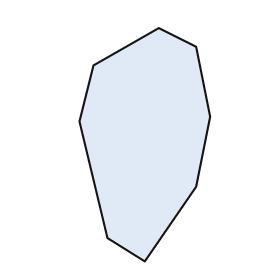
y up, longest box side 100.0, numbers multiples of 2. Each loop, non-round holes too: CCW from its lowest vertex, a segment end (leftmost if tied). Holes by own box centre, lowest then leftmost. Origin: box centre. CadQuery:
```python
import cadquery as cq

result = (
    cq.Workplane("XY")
    .moveTo(0.0, -50.0)
    .lineTo(22.0, -18.0)
    .lineTo(28.0, 12.0)
    .lineTo(22.0, 42.0)
    .lineTo(6.0, 50.0)
    .lineTo(-22.0, 34.0)
    .lineTo(-28.0, 10.0)
    .lineTo(-16.0, -40.0)
    .close()
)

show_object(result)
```